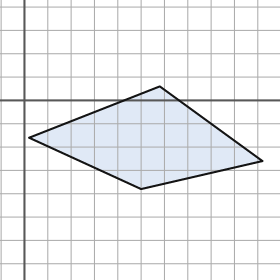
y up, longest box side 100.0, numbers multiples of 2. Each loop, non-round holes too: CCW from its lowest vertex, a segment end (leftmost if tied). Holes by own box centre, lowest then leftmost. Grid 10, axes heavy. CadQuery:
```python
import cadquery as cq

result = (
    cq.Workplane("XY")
    .moveTo(50.0, -38.0)
    .lineTo(102.0, -26.0)
    .lineTo(58.0, 6.0)
    .lineTo(2.0, -16.0)
    .close()
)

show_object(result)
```